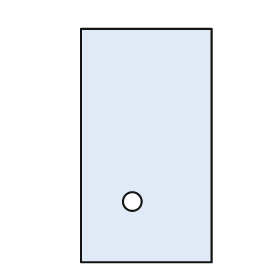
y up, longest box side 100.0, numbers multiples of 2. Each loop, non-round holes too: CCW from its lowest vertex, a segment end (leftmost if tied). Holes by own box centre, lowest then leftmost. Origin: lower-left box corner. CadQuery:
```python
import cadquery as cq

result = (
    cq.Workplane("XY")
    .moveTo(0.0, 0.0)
    .lineTo(56.0, 0.0)
    .lineTo(56.0, 100.0)
    .lineTo(0.0, 100.0)
    .close()
    .moveTo(22.0, 26.0)
    .circle(4.0)
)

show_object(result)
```